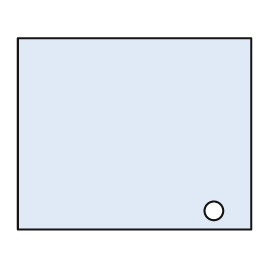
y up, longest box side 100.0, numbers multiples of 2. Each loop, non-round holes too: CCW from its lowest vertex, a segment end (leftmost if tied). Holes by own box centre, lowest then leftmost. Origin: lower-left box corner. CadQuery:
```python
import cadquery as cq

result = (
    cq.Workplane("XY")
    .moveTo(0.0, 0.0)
    .lineTo(100.0, 0.0)
    .lineTo(100.0, 82.0)
    .lineTo(0.0, 82.0)
    .close()
    .moveTo(84.0, 8.0)
    .circle(4.0)
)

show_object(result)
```